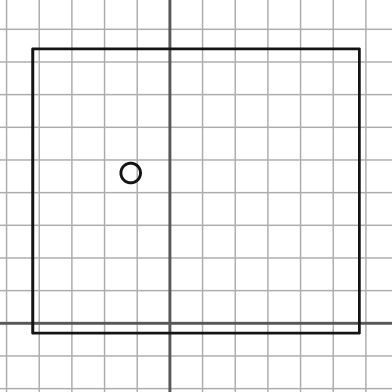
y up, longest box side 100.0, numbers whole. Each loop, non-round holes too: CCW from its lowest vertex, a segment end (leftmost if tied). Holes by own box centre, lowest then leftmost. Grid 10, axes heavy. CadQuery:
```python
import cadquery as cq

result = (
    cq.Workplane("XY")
    .moveTo(-42.0, -3.0)
    .lineTo(58.0, -3.0)
    .lineTo(58.0, 84.0)
    .lineTo(-42.0, 84.0)
    .close()
    .moveTo(-12.0, 46.0)
    .circle(3.0)
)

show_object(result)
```